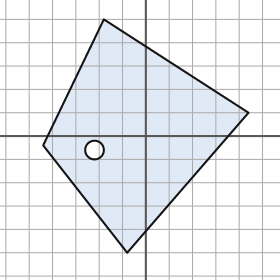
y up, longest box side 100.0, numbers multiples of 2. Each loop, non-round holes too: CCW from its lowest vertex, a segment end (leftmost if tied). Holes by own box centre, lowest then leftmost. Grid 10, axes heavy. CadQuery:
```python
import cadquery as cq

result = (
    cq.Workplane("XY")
    .moveTo(-8.0, -50.0)
    .lineTo(44.0, 10.0)
    .lineTo(-18.0, 50.0)
    .lineTo(-44.0, -4.0)
    .close()
    .moveTo(-22.0, -6.0)
    .circle(4.0)
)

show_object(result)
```